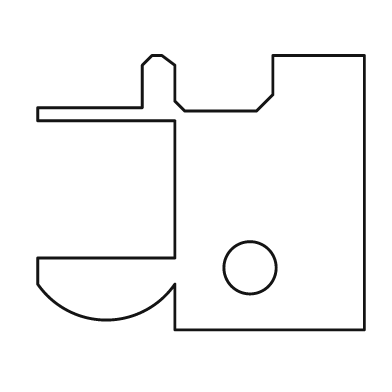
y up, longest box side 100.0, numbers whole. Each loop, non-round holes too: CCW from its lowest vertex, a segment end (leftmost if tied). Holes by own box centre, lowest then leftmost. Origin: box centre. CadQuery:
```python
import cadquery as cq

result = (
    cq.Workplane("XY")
    .moveTo(-8.0, -42.0)
    .lineTo(50.0, -42.0)
    .lineTo(50.0, 42.0)
    .lineTo(22.0, 42.0)
    .lineTo(22.0, 30.0)
    .lineTo(17.0, 25.0)
    .lineTo(-5.0, 25.0)
    .lineTo(-8.0, 28.0)
    .lineTo(-8.0, 39.0)
    .lineTo(-12.0, 42.0)
    .lineTo(-15.0, 42.0)
    .lineTo(-18.0, 39.0)
    .lineTo(-18.0, 26.0)
    .lineTo(-50.0, 26.0)
    .lineTo(-50.0, 22.0)
    .lineTo(-8.0, 22.0)
    .lineTo(-8.0, -20.0)
    .lineTo(-50.0, -20.0)
    .lineTo(-50.0, -28.0)
    .threePointArc((-29.0, -39.0), (-8.0, -28.0))
    .close()
    .moveTo(15.0, -23.0)
    .circle(8.0)
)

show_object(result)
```